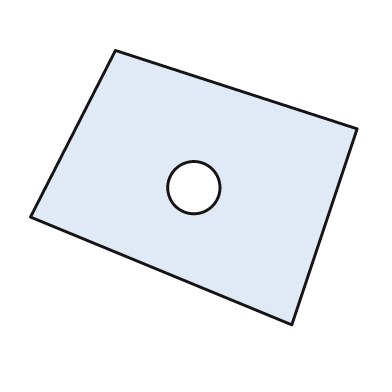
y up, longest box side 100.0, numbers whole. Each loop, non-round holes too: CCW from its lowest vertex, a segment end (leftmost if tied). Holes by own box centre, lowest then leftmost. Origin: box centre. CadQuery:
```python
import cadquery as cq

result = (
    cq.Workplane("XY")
    .moveTo(30.0, -42.0)
    .lineTo(50.0, 18.0)
    .lineTo(-24.0, 42.0)
    .lineTo(-50.0, -9.0)
    .close()
    .moveTo(0.0, 0.0)
    .circle(8.0)
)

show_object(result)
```